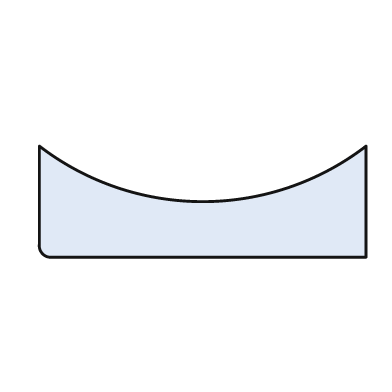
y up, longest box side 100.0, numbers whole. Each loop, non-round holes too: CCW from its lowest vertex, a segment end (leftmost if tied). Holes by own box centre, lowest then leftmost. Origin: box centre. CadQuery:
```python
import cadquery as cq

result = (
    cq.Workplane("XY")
    .moveTo(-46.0, -17.0)
    .lineTo(50.0, -17.0)
    .lineTo(50.0, 17.0)
    .threePointArc((0.0, 0.0), (-50.0, 17.0))
    .lineTo(-50.0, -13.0)
    .threePointArc((-49.0, -16.0), (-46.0, -17.0))
    .close()
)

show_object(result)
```